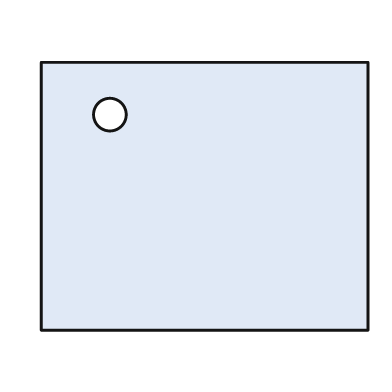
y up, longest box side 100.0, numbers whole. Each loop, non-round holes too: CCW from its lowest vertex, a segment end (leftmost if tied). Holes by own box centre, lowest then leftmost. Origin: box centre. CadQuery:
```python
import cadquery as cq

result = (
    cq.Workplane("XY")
    .moveTo(-50.0, -41.0)
    .lineTo(50.0, -41.0)
    .lineTo(50.0, 41.0)
    .lineTo(-50.0, 41.0)
    .close()
    .moveTo(-29.0, 25.0)
    .circle(5.0)
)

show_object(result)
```